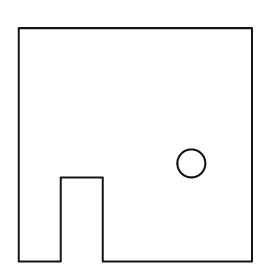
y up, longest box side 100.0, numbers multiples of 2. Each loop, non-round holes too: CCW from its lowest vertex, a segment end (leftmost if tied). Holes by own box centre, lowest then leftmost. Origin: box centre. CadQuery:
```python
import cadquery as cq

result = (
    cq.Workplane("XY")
    .moveTo(-50.0, -50.0)
    .lineTo(-32.0, -50.0)
    .lineTo(-32.0, -14.0)
    .lineTo(-14.0, -14.0)
    .lineTo(-14.0, -50.0)
    .lineTo(50.0, -50.0)
    .lineTo(50.0, 50.0)
    .lineTo(-50.0, 50.0)
    .close()
    .moveTo(24.0, -8.0)
    .circle(6.0)
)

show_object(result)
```